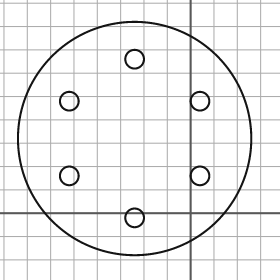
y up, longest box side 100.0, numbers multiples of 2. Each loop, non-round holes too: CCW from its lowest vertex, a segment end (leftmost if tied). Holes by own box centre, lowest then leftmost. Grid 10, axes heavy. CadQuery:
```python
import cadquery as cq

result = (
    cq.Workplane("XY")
    .moveTo(-24.0, 32.0)
    .circle(50.0)
    .moveTo(-24.0, -2.0)
    .circle(4.0)
    .moveTo(-52.0, 16.0)
    .circle(4.0)
    .moveTo(4.0, 16.0)
    .circle(4.0)
    .moveTo(-52.0, 48.0)
    .circle(4.0)
    .moveTo(4.0, 48.0)
    .circle(4.0)
    .moveTo(-24.0, 66.0)
    .circle(4.0)
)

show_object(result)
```